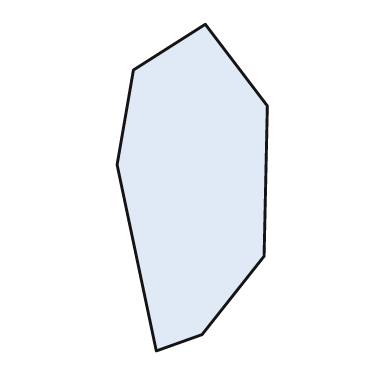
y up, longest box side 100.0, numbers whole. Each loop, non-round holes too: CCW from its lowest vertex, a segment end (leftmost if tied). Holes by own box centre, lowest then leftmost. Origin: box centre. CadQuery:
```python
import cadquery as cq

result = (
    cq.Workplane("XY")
    .moveTo(-11.0, -50.0)
    .lineTo(3.0, -45.0)
    .lineTo(22.0, -21.0)
    .lineTo(23.0, 25.0)
    .lineTo(4.0, 50.0)
    .lineTo(-18.0, 36.0)
    .lineTo(-23.0, 7.0)
    .close()
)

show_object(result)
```